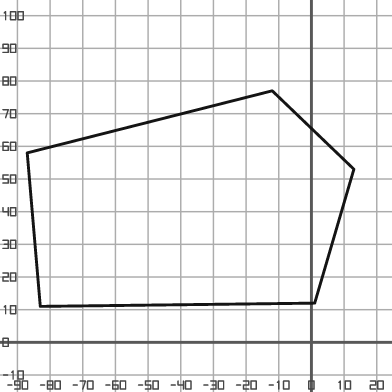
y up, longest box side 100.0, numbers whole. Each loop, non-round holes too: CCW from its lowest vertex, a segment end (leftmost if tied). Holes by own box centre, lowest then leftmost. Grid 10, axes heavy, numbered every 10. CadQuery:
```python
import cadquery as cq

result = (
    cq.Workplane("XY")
    .moveTo(-83.0, 11.0)
    .lineTo(1.0, 12.0)
    .lineTo(13.0, 53.0)
    .lineTo(-12.0, 77.0)
    .lineTo(-87.0, 58.0)
    .close()
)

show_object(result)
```